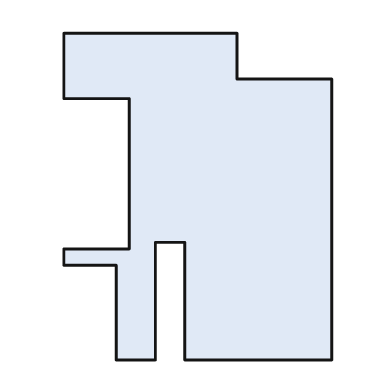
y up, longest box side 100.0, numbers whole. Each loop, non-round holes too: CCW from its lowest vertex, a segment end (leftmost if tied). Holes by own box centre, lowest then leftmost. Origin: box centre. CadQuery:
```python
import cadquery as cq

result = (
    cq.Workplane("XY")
    .moveTo(-25.0, -50.0)
    .lineTo(-13.0, -50.0)
    .lineTo(-13.0, -14.0)
    .lineTo(-4.0, -14.0)
    .lineTo(-4.0, -50.0)
    .lineTo(41.0, -50.0)
    .lineTo(41.0, 36.0)
    .lineTo(12.0, 36.0)
    .lineTo(12.0, 50.0)
    .lineTo(-41.0, 50.0)
    .lineTo(-41.0, 30.0)
    .lineTo(-21.0, 30.0)
    .lineTo(-21.0, -16.0)
    .lineTo(-41.0, -16.0)
    .lineTo(-41.0, -21.0)
    .lineTo(-25.0, -21.0)
    .close()
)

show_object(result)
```